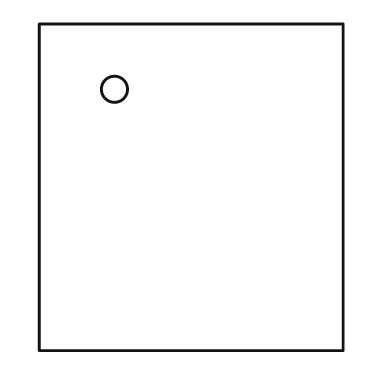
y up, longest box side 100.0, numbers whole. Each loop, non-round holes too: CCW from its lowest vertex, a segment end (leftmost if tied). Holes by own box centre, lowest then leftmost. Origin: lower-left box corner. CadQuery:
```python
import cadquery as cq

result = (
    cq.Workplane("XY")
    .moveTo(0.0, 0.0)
    .lineTo(93.0, 0.0)
    .lineTo(93.0, 100.0)
    .lineTo(0.0, 100.0)
    .close()
    .moveTo(23.0, 80.0)
    .circle(4.0)
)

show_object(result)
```